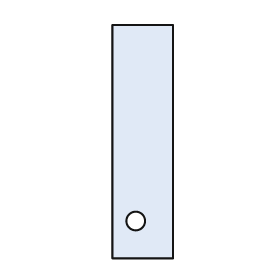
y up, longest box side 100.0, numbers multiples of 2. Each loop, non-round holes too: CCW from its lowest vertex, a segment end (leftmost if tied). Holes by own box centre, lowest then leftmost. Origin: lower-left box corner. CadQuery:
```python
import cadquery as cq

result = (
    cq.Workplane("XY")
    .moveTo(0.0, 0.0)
    .lineTo(26.0, 0.0)
    .lineTo(26.0, 100.0)
    .lineTo(0.0, 100.0)
    .close()
    .moveTo(10.0, 16.0)
    .circle(4.0)
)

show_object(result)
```